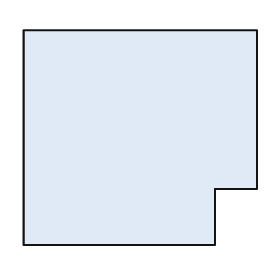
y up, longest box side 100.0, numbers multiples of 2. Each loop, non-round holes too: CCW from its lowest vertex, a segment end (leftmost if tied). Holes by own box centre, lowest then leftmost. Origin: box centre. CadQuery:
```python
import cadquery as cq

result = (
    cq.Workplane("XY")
    .moveTo(-50.0, -46.0)
    .lineTo(32.0, -46.0)
    .lineTo(32.0, -22.0)
    .lineTo(50.0, -22.0)
    .lineTo(50.0, 46.0)
    .lineTo(-50.0, 46.0)
    .close()
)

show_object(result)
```